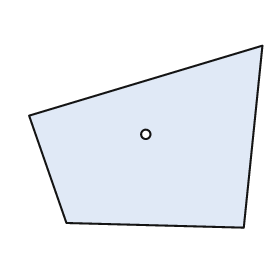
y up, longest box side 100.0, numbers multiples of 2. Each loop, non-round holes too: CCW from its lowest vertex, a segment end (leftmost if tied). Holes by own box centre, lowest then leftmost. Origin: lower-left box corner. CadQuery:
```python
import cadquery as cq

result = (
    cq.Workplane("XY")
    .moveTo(92.0, 0.0)
    .lineTo(100.0, 78.0)
    .lineTo(0.0, 48.0)
    .lineTo(16.0, 2.0)
    .close()
    .moveTo(50.0, 40.0)
    .circle(2.0)
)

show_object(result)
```